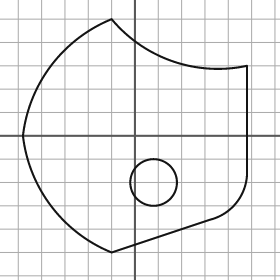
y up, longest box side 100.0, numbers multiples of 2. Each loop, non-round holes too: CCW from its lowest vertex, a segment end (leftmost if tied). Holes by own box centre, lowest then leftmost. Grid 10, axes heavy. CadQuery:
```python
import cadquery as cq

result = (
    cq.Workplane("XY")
    .moveTo(-10.0, -50.0)
    .lineTo(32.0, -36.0)
    .threePointArc((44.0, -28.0), (48.0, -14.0))
    .lineTo(48.0, 30.0)
    .threePointArc((16.0, 32.0), (-10.0, 50.0))
    .threePointArc((-36.0, 30.0), (-48.0, 0.0))
    .threePointArc((-36.0, -30.0), (-10.0, -50.0))
    .close()
    .moveTo(8.0, -20.0)
    .circle(10.0)
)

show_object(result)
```